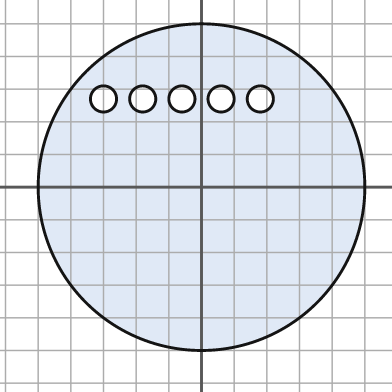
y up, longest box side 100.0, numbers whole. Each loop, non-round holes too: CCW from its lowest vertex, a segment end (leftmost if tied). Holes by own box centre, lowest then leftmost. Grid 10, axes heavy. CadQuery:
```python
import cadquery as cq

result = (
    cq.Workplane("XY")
    .moveTo(0.0, 0.0)
    .circle(50.0)
    .moveTo(-30.0, 27.0)
    .circle(4.0)
    .moveTo(-18.0, 27.0)
    .circle(4.0)
    .moveTo(-6.0, 27.0)
    .circle(4.0)
    .moveTo(6.0, 27.0)
    .circle(4.0)
    .moveTo(18.0, 27.0)
    .circle(4.0)
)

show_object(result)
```